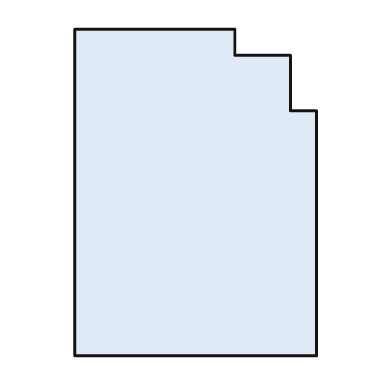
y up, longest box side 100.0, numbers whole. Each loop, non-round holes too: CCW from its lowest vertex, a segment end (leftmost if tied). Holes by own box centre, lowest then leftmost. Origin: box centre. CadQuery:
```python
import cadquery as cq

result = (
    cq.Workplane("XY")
    .moveTo(-37.0, -50.0)
    .lineTo(37.0, -50.0)
    .lineTo(37.0, 25.0)
    .lineTo(29.0, 25.0)
    .lineTo(29.0, 42.0)
    .lineTo(12.0, 42.0)
    .lineTo(12.0, 50.0)
    .lineTo(-37.0, 50.0)
    .close()
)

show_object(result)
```